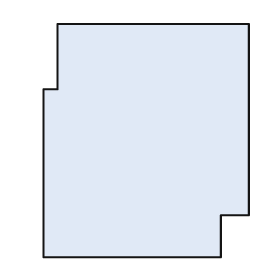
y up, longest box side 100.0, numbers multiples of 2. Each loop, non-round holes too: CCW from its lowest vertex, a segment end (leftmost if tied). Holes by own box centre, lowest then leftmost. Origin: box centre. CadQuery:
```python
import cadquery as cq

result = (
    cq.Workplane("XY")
    .moveTo(-44.0, -50.0)
    .lineTo(32.0, -50.0)
    .lineTo(32.0, -32.0)
    .lineTo(44.0, -32.0)
    .lineTo(44.0, 50.0)
    .lineTo(-38.0, 50.0)
    .lineTo(-38.0, 22.0)
    .lineTo(-44.0, 22.0)
    .close()
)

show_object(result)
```